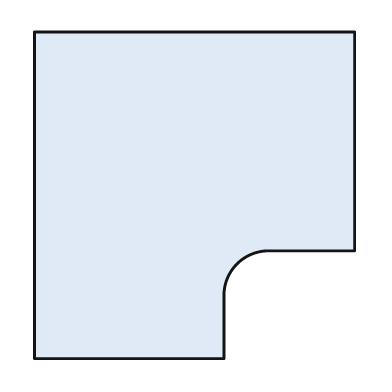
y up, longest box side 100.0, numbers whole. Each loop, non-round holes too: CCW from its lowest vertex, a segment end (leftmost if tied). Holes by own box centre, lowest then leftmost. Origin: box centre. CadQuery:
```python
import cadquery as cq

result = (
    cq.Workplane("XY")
    .moveTo(-49.0, -50.0)
    .lineTo(9.0, -50.0)
    .lineTo(9.0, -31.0)
    .threePointArc((13.0, -21.0), (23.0, -17.0))
    .lineTo(49.0, -17.0)
    .lineTo(49.0, 50.0)
    .lineTo(-49.0, 50.0)
    .close()
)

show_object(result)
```